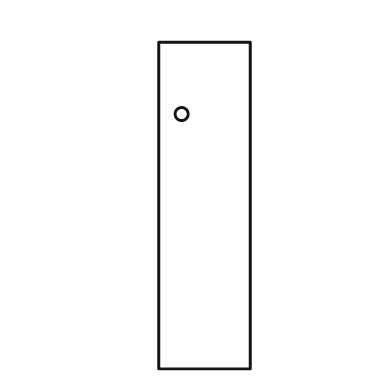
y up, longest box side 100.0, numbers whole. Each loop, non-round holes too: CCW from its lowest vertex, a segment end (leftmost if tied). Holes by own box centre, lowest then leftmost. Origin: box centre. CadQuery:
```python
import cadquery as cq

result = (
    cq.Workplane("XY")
    .moveTo(-14.0, -50.0)
    .lineTo(14.0, -50.0)
    .lineTo(14.0, 50.0)
    .lineTo(-14.0, 50.0)
    .close()
    .moveTo(-7.0, 28.0)
    .circle(2.0)
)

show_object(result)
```